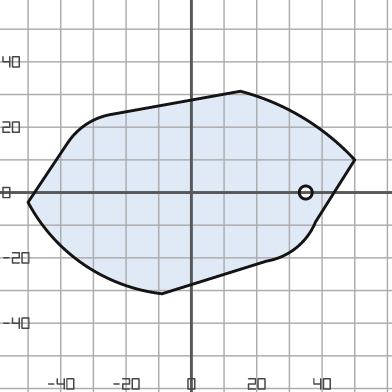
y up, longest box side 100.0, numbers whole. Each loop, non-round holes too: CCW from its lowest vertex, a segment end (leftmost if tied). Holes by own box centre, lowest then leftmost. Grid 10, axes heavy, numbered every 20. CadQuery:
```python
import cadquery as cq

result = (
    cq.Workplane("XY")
    .moveTo(-9.0, -31.0)
    .lineTo(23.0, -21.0)
    .threePointArc((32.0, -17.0), (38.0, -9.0))
    .lineTo(50.0, 10.0)
    .threePointArc((34.0, 23.0), (15.0, 31.0))
    .lineTo(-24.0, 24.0)
    .threePointArc((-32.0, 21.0), (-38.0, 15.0))
    .lineTo(-50.0, -3.0)
    .threePointArc((-33.0, -22.0), (-9.0, -31.0))
    .close()
    .moveTo(35.0, 0.0)
    .circle(2.0)
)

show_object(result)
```